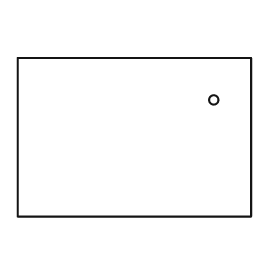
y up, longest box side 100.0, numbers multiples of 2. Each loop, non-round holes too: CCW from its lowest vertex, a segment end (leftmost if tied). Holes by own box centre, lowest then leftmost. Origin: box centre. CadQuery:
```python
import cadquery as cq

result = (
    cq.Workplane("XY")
    .moveTo(-50.0, -34.0)
    .lineTo(50.0, -34.0)
    .lineTo(50.0, 34.0)
    .lineTo(-50.0, 34.0)
    .close()
    .moveTo(34.0, 16.0)
    .circle(2.0)
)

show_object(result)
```